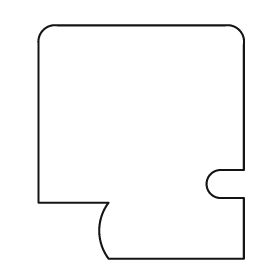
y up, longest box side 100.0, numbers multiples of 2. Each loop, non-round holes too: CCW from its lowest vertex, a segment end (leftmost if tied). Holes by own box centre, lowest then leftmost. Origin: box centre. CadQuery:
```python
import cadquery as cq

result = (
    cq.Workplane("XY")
    .moveTo(-14.0, -50.0)
    .lineTo(44.0, -50.0)
    .lineTo(44.0, -24.0)
    .lineTo(34.0, -24.0)
    .threePointArc((28.0, -18.0), (34.0, -12.0))
    .lineTo(44.0, -12.0)
    .lineTo(44.0, 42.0)
    .threePointArc((42.0, 48.0), (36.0, 50.0))
    .lineTo(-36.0, 50.0)
    .threePointArc((-42.0, 48.0), (-44.0, 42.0))
    .lineTo(-44.0, -26.0)
    .lineTo(-14.0, -26.0)
    .threePointArc((-18.0, -38.0), (-14.0, -50.0))
    .close()
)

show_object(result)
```